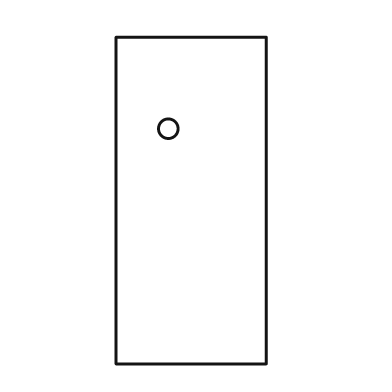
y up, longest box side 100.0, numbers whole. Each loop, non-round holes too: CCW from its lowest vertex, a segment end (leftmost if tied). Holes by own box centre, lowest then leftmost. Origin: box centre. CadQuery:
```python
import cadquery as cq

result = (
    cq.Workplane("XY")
    .moveTo(-23.0, -50.0)
    .lineTo(23.0, -50.0)
    .lineTo(23.0, 50.0)
    .lineTo(-23.0, 50.0)
    .close()
    .moveTo(-7.0, 22.0)
    .circle(3.0)
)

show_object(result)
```